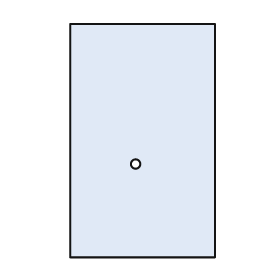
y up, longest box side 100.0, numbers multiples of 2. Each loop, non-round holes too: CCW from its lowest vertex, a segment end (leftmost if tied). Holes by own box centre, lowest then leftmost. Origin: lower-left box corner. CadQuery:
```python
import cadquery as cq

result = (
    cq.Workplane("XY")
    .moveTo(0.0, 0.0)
    .lineTo(62.0, 0.0)
    .lineTo(62.0, 100.0)
    .lineTo(0.0, 100.0)
    .close()
    .moveTo(28.0, 40.0)
    .circle(2.0)
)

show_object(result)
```